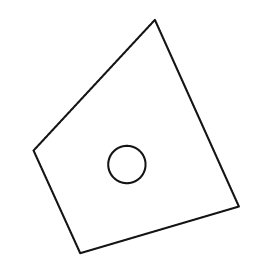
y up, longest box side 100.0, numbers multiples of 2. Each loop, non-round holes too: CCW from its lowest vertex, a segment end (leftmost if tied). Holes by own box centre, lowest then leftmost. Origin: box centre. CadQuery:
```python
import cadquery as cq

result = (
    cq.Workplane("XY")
    .moveTo(-24.0, -50.0)
    .lineTo(44.0, -30.0)
    .lineTo(8.0, 50.0)
    .lineTo(-44.0, -6.0)
    .close()
    .moveTo(-4.0, -12.0)
    .circle(8.0)
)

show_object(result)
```